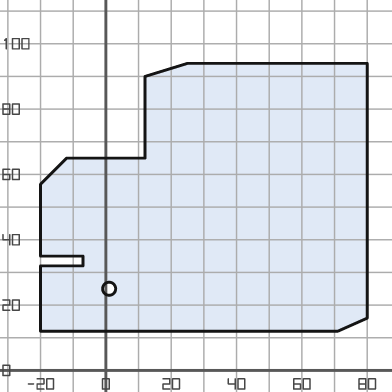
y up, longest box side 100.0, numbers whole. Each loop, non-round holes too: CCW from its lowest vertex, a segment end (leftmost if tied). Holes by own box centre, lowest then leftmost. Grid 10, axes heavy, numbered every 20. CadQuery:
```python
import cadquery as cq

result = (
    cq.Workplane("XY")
    .moveTo(-20.0, 12.0)
    .lineTo(71.0, 12.0)
    .lineTo(80.0, 16.0)
    .lineTo(80.0, 94.0)
    .lineTo(25.0, 94.0)
    .lineTo(12.0, 90.0)
    .lineTo(12.0, 65.0)
    .lineTo(-12.0, 65.0)
    .lineTo(-20.0, 57.0)
    .lineTo(-20.0, 35.0)
    .lineTo(-7.0, 35.0)
    .lineTo(-7.0, 32.0)
    .lineTo(-20.0, 32.0)
    .close()
    .moveTo(1.0, 25.0)
    .circle(2.0)
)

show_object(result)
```